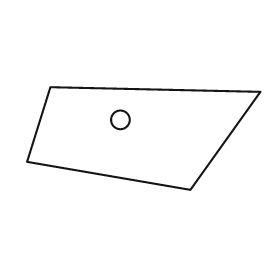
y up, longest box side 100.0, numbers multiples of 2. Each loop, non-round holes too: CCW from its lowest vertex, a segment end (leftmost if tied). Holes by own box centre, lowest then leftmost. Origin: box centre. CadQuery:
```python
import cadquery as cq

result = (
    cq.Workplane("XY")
    .moveTo(20.0, -22.0)
    .lineTo(50.0, 20.0)
    .lineTo(-40.0, 22.0)
    .lineTo(-50.0, -10.0)
    .close()
    .moveTo(-10.0, 8.0)
    .circle(4.0)
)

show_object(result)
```